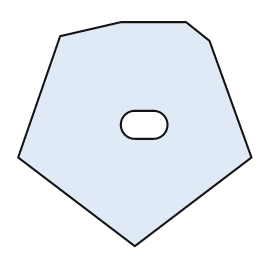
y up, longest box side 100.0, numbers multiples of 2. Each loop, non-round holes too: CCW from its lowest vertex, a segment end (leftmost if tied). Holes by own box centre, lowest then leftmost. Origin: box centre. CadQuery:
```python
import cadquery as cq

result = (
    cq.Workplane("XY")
    .moveTo(0.0, -48.0)
    .lineTo(50.0, -10.0)
    .lineTo(32.0, 40.0)
    .lineTo(22.0, 48.0)
    .lineTo(-6.0, 48.0)
    .lineTo(-32.0, 42.0)
    .lineTo(-50.0, -10.0)
    .close()
    .moveTo(0.0, -2.0)
    .lineTo(8.0, -2.0)
    .threePointArc((14.0, 4.0), (8.0, 10.0))
    .lineTo(0.0, 10.0)
    .threePointArc((-6.0, 4.0), (0.0, -2.0))
    .close()
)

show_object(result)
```